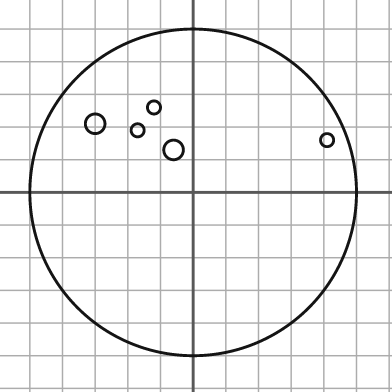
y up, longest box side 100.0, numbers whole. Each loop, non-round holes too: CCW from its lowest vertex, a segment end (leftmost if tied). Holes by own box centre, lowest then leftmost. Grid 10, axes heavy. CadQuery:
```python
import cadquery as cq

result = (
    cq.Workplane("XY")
    .moveTo(0.0, 0.0)
    .circle(50.0)
    .moveTo(-6.0, 13.0)
    .circle(3.0)
    .moveTo(41.0, 16.0)
    .circle(2.0)
    .moveTo(-17.0, 19.0)
    .circle(2.0)
    .moveTo(-30.0, 21.0)
    .circle(3.0)
    .moveTo(-12.0, 26.0)
    .circle(2.0)
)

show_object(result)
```